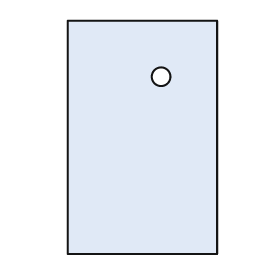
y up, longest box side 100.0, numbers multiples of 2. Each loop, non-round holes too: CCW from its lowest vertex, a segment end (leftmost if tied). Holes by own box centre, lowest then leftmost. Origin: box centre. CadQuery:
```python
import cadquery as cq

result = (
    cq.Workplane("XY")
    .moveTo(-32.0, -50.0)
    .lineTo(32.0, -50.0)
    .lineTo(32.0, 50.0)
    .lineTo(-32.0, 50.0)
    .close()
    .moveTo(8.0, 26.0)
    .circle(4.0)
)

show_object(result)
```